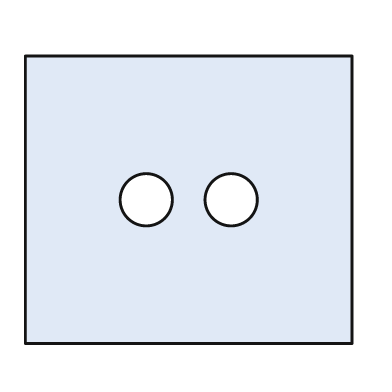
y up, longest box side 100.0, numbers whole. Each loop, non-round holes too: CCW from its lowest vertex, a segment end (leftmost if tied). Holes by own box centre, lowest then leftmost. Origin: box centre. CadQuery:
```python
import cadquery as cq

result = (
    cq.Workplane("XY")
    .moveTo(-50.0, -44.0)
    .lineTo(50.0, -44.0)
    .lineTo(50.0, 44.0)
    .lineTo(-50.0, 44.0)
    .close()
    .moveTo(-13.0, 0.0)
    .circle(8.0)
    .moveTo(13.0, 0.0)
    .circle(8.0)
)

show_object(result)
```